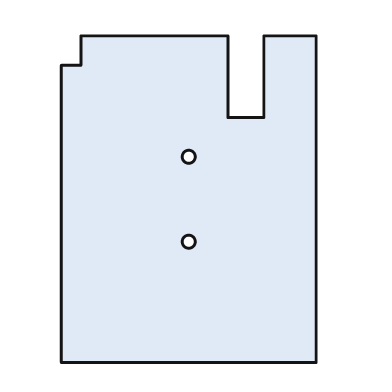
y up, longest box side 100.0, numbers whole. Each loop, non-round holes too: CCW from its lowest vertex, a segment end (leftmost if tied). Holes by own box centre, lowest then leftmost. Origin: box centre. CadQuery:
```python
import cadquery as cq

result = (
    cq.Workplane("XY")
    .moveTo(-39.0, -50.0)
    .lineTo(39.0, -50.0)
    .lineTo(39.0, 50.0)
    .lineTo(23.0, 50.0)
    .lineTo(23.0, 25.0)
    .lineTo(12.0, 25.0)
    .lineTo(12.0, 50.0)
    .lineTo(-33.0, 50.0)
    .lineTo(-33.0, 41.0)
    .lineTo(-39.0, 41.0)
    .close()
    .moveTo(0.0, -13.0)
    .circle(2.0)
    .moveTo(0.0, 13.0)
    .circle(2.0)
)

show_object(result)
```